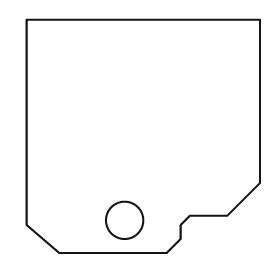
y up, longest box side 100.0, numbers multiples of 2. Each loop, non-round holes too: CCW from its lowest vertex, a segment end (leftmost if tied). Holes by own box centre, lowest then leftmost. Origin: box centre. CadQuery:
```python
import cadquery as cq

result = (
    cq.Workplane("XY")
    .moveTo(-36.0, -50.0)
    .lineTo(10.0, -50.0)
    .lineTo(16.0, -44.0)
    .lineTo(16.0, -38.0)
    .lineTo(20.0, -34.0)
    .lineTo(36.0, -34.0)
    .lineTo(50.0, -20.0)
    .lineTo(50.0, 50.0)
    .lineTo(-50.0, 50.0)
    .lineTo(-50.0, -38.0)
    .close()
    .moveTo(-8.0, -36.0)
    .circle(8.0)
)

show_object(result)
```